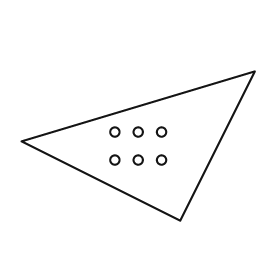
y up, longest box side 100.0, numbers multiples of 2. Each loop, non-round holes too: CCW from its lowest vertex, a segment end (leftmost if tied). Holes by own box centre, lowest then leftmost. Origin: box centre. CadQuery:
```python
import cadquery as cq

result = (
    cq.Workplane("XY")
    .moveTo(18.0, -32.0)
    .lineTo(50.0, 32.0)
    .lineTo(-50.0, 2.0)
    .close()
    .moveTo(-10.0, -6.0)
    .circle(2.0)
    .moveTo(0.0, -6.0)
    .circle(2.0)
    .moveTo(10.0, -6.0)
    .circle(2.0)
    .moveTo(-10.0, 6.0)
    .circle(2.0)
    .moveTo(0.0, 6.0)
    .circle(2.0)
    .moveTo(10.0, 6.0)
    .circle(2.0)
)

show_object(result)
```